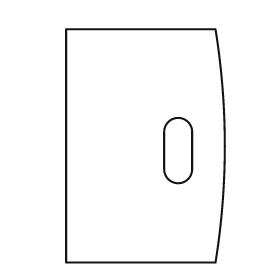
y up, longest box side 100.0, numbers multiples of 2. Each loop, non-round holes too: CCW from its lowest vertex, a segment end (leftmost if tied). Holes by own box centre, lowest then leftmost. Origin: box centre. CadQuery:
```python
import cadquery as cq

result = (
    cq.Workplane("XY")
    .moveTo(-34.0, -50.0)
    .lineTo(30.0, -50.0)
    .threePointArc((34.0, 0.0), (30.0, 50.0))
    .lineTo(-34.0, 50.0)
    .close()
    .moveTo(8.0, -10.0)
    .threePointArc((14.0, -16.0), (20.0, -10.0))
    .lineTo(20.0, 6.0)
    .threePointArc((14.0, 12.0), (8.0, 6.0))
    .close()
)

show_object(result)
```